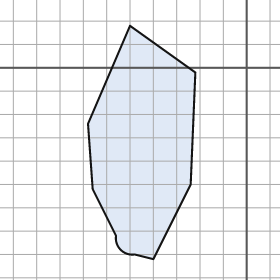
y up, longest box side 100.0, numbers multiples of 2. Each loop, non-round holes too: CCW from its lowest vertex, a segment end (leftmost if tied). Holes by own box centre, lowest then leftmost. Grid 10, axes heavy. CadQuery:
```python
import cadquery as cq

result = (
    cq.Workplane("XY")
    .moveTo(-40.0, -82.0)
    .lineTo(-24.0, -50.0)
    .lineTo(-22.0, -2.0)
    .lineTo(-50.0, 18.0)
    .lineTo(-68.0, -24.0)
    .lineTo(-66.0, -52.0)
    .lineTo(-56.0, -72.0)
    .threePointArc((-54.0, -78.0), (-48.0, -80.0))
    .close()
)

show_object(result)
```